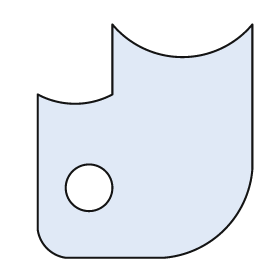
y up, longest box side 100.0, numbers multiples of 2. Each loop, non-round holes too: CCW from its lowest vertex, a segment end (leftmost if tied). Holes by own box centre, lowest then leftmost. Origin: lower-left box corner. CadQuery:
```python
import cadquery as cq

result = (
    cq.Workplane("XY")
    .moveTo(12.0, 0.0)
    .lineTo(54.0, 0.0)
    .threePointArc((80.0, 12.0), (92.0, 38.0))
    .lineTo(92.0, 100.0)
    .threePointArc((62.0, 86.0), (32.0, 100.0))
    .lineTo(32.0, 70.0)
    .threePointArc((16.0, 66.0), (0.0, 70.0))
    .lineTo(0.0, 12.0)
    .threePointArc((4.0, 4.0), (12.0, 0.0))
    .close()
    .moveTo(22.0, 30.0)
    .circle(10.0)
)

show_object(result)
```